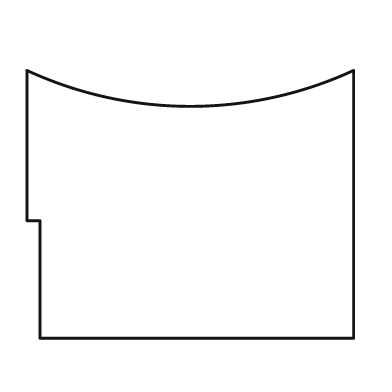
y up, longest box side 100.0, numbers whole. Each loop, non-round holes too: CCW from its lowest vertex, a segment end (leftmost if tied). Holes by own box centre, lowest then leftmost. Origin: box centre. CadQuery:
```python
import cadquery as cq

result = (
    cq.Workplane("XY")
    .moveTo(-46.0, -41.0)
    .lineTo(50.0, -41.0)
    .lineTo(50.0, 41.0)
    .threePointArc((0.0, 30.0), (-50.0, 41.0))
    .lineTo(-50.0, -5.0)
    .lineTo(-46.0, -5.0)
    .close()
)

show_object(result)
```